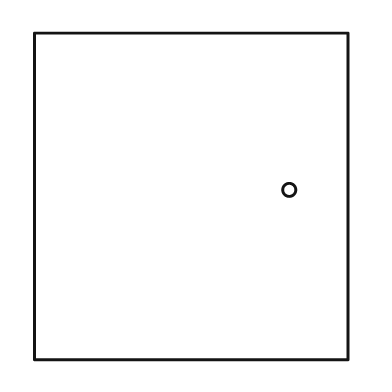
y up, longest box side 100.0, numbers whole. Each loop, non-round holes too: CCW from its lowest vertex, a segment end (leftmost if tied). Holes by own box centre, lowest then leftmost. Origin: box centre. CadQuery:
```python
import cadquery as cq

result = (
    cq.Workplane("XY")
    .moveTo(-48.0, -50.0)
    .lineTo(48.0, -50.0)
    .lineTo(48.0, 50.0)
    .lineTo(-48.0, 50.0)
    .close()
    .moveTo(30.0, 2.0)
    .circle(2.0)
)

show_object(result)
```